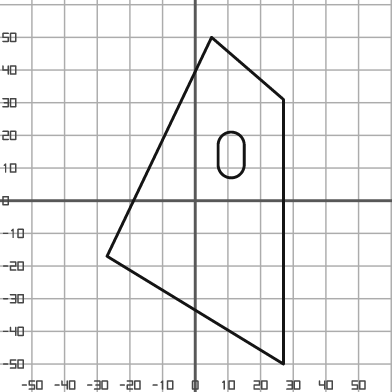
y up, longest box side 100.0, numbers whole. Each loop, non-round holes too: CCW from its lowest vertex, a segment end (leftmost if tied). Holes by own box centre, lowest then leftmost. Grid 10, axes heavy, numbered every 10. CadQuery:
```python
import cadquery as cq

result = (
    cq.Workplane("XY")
    .moveTo(27.0, -50.0)
    .lineTo(27.0, 31.0)
    .lineTo(5.0, 50.0)
    .lineTo(-27.0, -17.0)
    .close()
    .moveTo(7.0, 11.0)
    .threePointArc((11.0, 7.0), (15.0, 11.0))
    .lineTo(15.0, 17.0)
    .threePointArc((11.0, 21.0), (7.0, 17.0))
    .close()
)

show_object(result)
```